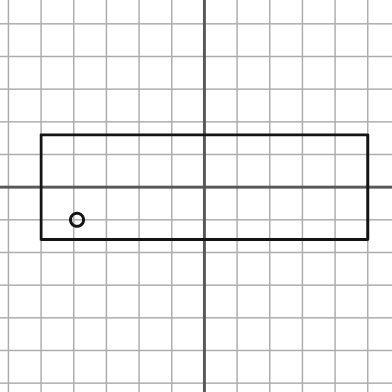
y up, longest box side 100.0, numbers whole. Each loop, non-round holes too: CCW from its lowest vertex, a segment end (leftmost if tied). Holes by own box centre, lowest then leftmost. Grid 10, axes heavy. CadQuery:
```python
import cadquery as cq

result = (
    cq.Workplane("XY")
    .moveTo(-50.0, -16.0)
    .lineTo(50.0, -16.0)
    .lineTo(50.0, 16.0)
    .lineTo(-50.0, 16.0)
    .close()
    .moveTo(-39.0, -10.0)
    .circle(2.0)
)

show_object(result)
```